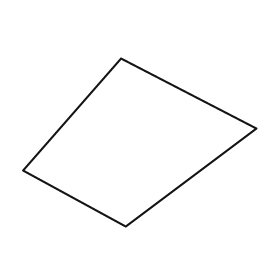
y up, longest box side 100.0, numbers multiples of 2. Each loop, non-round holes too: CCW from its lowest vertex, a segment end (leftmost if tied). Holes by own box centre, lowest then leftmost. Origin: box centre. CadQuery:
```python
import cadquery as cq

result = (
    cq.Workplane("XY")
    .moveTo(-6.0, -36.0)
    .lineTo(50.0, 6.0)
    .lineTo(-8.0, 36.0)
    .lineTo(-50.0, -12.0)
    .close()
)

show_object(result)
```